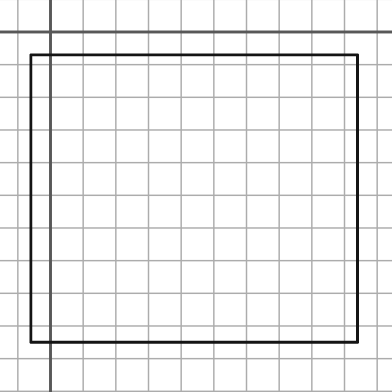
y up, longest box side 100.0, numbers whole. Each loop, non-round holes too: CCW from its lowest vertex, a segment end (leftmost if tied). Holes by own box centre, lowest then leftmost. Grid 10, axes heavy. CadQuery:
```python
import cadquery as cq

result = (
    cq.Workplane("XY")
    .moveTo(-6.0, -95.0)
    .lineTo(94.0, -95.0)
    .lineTo(94.0, -7.0)
    .lineTo(-6.0, -7.0)
    .close()
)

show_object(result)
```